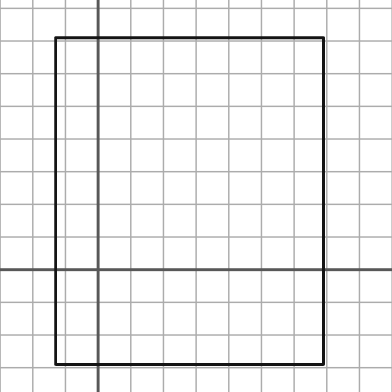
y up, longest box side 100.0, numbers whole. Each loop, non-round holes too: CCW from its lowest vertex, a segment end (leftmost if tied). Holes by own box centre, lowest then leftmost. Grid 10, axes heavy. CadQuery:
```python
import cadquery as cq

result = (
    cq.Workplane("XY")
    .moveTo(-13.0, -29.0)
    .lineTo(69.0, -29.0)
    .lineTo(69.0, 71.0)
    .lineTo(-13.0, 71.0)
    .close()
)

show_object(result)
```